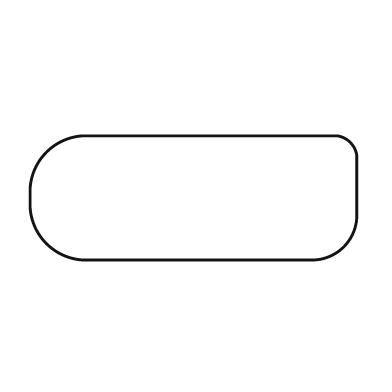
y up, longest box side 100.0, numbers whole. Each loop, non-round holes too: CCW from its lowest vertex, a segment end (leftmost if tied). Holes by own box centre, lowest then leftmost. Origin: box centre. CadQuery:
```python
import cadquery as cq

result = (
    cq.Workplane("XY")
    .moveTo(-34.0, -19.0)
    .lineTo(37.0, -19.0)
    .threePointArc((46.0, -15.0), (50.0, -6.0))
    .lineTo(50.0, 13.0)
    .threePointArc((48.0, 17.0), (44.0, 19.0))
    .lineTo(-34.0, 19.0)
    .threePointArc((-45.0, 14.0), (-50.0, 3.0))
    .lineTo(-50.0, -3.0)
    .threePointArc((-45.0, -14.0), (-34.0, -19.0))
    .close()
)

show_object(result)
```